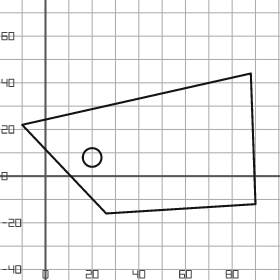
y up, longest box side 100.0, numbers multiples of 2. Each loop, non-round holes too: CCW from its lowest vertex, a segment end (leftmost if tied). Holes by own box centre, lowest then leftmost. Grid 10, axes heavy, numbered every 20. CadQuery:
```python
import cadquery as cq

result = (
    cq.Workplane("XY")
    .moveTo(26.0, -16.0)
    .lineTo(90.0, -12.0)
    .lineTo(88.0, 44.0)
    .lineTo(-10.0, 22.0)
    .close()
    .moveTo(20.0, 8.0)
    .circle(4.0)
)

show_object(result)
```